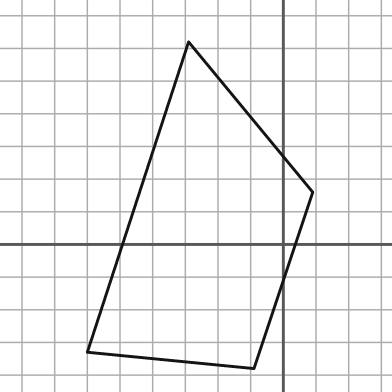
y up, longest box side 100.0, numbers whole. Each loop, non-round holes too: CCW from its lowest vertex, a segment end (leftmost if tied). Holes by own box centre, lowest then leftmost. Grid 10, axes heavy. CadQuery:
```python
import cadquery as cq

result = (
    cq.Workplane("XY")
    .moveTo(-9.0, -38.0)
    .lineTo(9.0, 16.0)
    .lineTo(-29.0, 62.0)
    .lineTo(-60.0, -33.0)
    .close()
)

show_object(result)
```